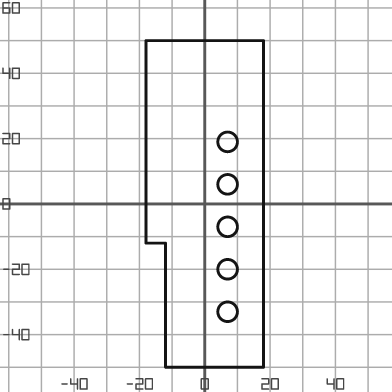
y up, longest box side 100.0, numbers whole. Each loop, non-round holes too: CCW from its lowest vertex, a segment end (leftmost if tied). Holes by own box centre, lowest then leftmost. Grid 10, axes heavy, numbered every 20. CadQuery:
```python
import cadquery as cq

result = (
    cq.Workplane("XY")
    .moveTo(-12.0, -50.0)
    .lineTo(18.0, -50.0)
    .lineTo(18.0, 50.0)
    .lineTo(-18.0, 50.0)
    .lineTo(-18.0, -12.0)
    .lineTo(-12.0, -12.0)
    .close()
    .moveTo(7.0, -33.0)
    .circle(3.0)
    .moveTo(7.0, -20.0)
    .circle(3.0)
    .moveTo(7.0, -7.0)
    .circle(3.0)
    .moveTo(7.0, 6.0)
    .circle(3.0)
    .moveTo(7.0, 19.0)
    .circle(3.0)
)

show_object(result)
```